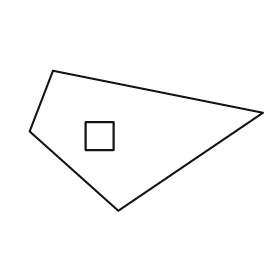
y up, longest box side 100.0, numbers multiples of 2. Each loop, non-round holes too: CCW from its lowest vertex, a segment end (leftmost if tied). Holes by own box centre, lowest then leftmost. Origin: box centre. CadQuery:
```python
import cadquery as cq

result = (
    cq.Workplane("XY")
    .moveTo(-12.0, -30.0)
    .lineTo(50.0, 12.0)
    .lineTo(-40.0, 30.0)
    .lineTo(-50.0, 4.0)
    .close()
    .moveTo(-26.0, -4.0)
    .lineTo(-14.0, -4.0)
    .lineTo(-14.0, 8.0)
    .lineTo(-26.0, 8.0)
    .close()
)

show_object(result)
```